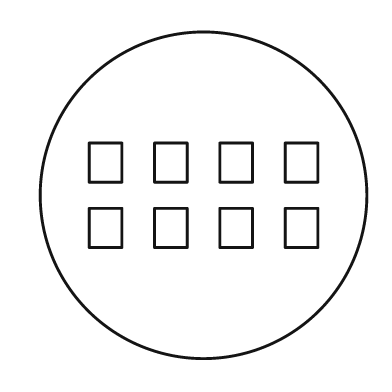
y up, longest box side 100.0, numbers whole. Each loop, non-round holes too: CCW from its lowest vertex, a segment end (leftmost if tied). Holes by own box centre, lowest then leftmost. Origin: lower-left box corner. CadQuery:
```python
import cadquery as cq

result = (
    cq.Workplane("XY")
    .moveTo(50.0, 50.0)
    .circle(50.0)
    .moveTo(15.0, 34.0)
    .lineTo(25.0, 34.0)
    .lineTo(25.0, 46.0)
    .lineTo(15.0, 46.0)
    .close()
    .moveTo(35.0, 34.0)
    .lineTo(45.0, 34.0)
    .lineTo(45.0, 46.0)
    .lineTo(35.0, 46.0)
    .close()
    .moveTo(55.0, 34.0)
    .lineTo(65.0, 34.0)
    .lineTo(65.0, 46.0)
    .lineTo(55.0, 46.0)
    .close()
    .moveTo(75.0, 34.0)
    .lineTo(85.0, 34.0)
    .lineTo(85.0, 46.0)
    .lineTo(75.0, 46.0)
    .close()
    .moveTo(15.0, 54.0)
    .lineTo(25.0, 54.0)
    .lineTo(25.0, 66.0)
    .lineTo(15.0, 66.0)
    .close()
    .moveTo(35.0, 54.0)
    .lineTo(45.0, 54.0)
    .lineTo(45.0, 66.0)
    .lineTo(35.0, 66.0)
    .close()
    .moveTo(55.0, 54.0)
    .lineTo(65.0, 54.0)
    .lineTo(65.0, 66.0)
    .lineTo(55.0, 66.0)
    .close()
    .moveTo(75.0, 54.0)
    .lineTo(85.0, 54.0)
    .lineTo(85.0, 66.0)
    .lineTo(75.0, 66.0)
    .close()
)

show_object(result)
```